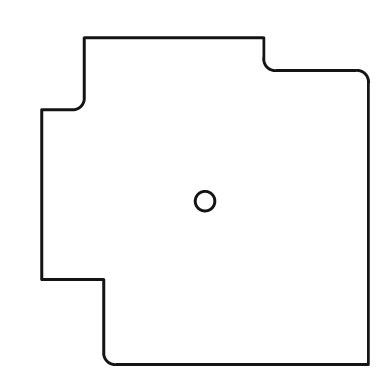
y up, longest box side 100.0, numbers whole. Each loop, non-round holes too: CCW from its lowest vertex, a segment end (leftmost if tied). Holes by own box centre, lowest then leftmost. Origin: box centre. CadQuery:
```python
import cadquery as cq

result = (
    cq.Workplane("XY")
    .moveTo(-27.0, -50.0)
    .lineTo(50.0, -50.0)
    .lineTo(50.0, 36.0)
    .threePointArc((49.0, 39.0), (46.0, 40.0))
    .lineTo(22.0, 40.0)
    .threePointArc((19.0, 41.0), (18.0, 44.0))
    .lineTo(18.0, 50.0)
    .lineTo(-37.0, 50.0)
    .lineTo(-37.0, 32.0)
    .threePointArc((-38.0, 29.0), (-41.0, 28.0))
    .lineTo(-50.0, 28.0)
    .lineTo(-50.0, -24.0)
    .lineTo(-31.0, -24.0)
    .lineTo(-31.0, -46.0)
    .threePointArc((-30.0, -49.0), (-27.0, -50.0))
    .close()
    .moveTo(0.0, 0.0)
    .circle(3.0)
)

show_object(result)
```